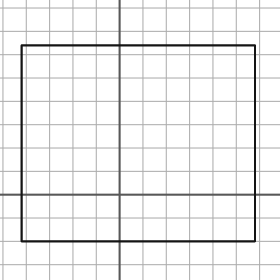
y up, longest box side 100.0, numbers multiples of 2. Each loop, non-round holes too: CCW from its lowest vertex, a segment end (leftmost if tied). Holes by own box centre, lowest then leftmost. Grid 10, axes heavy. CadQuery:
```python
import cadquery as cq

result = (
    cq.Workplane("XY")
    .moveTo(-42.0, -20.0)
    .lineTo(58.0, -20.0)
    .lineTo(58.0, 64.0)
    .lineTo(-42.0, 64.0)
    .close()
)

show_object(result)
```